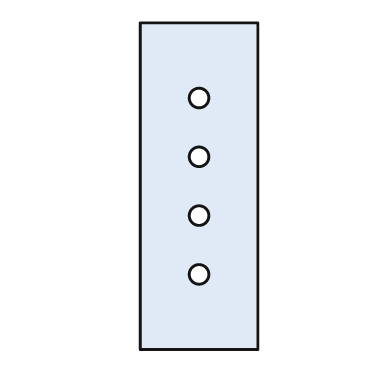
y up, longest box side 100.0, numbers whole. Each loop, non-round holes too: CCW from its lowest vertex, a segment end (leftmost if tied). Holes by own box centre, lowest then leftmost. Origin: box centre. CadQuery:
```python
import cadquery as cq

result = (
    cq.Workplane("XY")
    .moveTo(-18.0, -50.0)
    .lineTo(18.0, -50.0)
    .lineTo(18.0, 50.0)
    .lineTo(-18.0, 50.0)
    .close()
    .moveTo(0.0, -27.0)
    .circle(3.0)
    .moveTo(0.0, -9.0)
    .circle(3.0)
    .moveTo(0.0, 9.0)
    .circle(3.0)
    .moveTo(0.0, 27.0)
    .circle(3.0)
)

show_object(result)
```